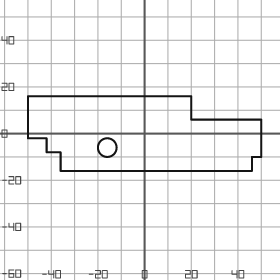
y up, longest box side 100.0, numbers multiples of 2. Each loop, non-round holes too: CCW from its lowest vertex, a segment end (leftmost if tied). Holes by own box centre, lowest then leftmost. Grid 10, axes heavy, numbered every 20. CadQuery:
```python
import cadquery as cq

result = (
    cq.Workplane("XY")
    .moveTo(-36.0, -16.0)
    .lineTo(46.0, -16.0)
    .lineTo(46.0, -10.0)
    .lineTo(50.0, -10.0)
    .lineTo(50.0, 6.0)
    .lineTo(20.0, 6.0)
    .lineTo(20.0, 16.0)
    .lineTo(-50.0, 16.0)
    .lineTo(-50.0, -2.0)
    .lineTo(-42.0, -2.0)
    .lineTo(-42.0, -8.0)
    .lineTo(-36.0, -8.0)
    .close()
    .moveTo(-16.0, -6.0)
    .circle(4.0)
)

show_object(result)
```